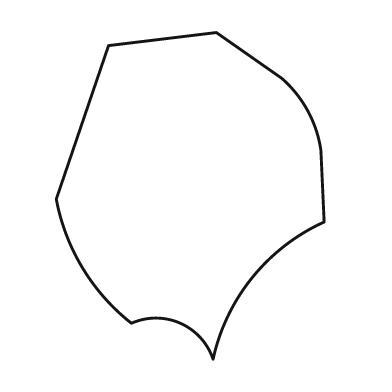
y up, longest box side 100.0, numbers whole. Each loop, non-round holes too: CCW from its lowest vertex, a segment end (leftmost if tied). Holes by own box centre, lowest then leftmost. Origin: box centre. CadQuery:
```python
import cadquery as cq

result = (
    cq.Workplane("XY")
    .moveTo(7.0, -50.0)
    .threePointArc((19.0, -25.0), (41.0, -8.0))
    .lineTo(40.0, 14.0)
    .threePointArc((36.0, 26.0), (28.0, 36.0))
    .lineTo(8.0, 50.0)
    .lineTo(-25.0, 46.0)
    .lineTo(-41.0, -1.0)
    .threePointArc((-33.0, -22.0), (-18.0, -39.0))
    .threePointArc((-3.0, -39.0), (7.0, -50.0))
    .close()
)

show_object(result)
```